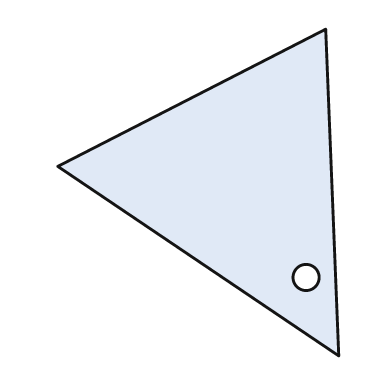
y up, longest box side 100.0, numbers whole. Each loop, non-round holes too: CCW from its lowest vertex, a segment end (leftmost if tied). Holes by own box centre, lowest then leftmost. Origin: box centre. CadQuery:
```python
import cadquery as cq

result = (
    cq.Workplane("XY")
    .moveTo(43.0, -50.0)
    .lineTo(39.0, 50.0)
    .lineTo(-43.0, 8.0)
    .close()
    .moveTo(33.0, -26.0)
    .circle(4.0)
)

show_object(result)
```